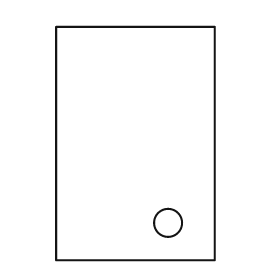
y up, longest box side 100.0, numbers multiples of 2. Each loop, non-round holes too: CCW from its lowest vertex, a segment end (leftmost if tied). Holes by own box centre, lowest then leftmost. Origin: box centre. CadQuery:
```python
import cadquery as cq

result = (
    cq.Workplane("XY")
    .moveTo(-34.0, -50.0)
    .lineTo(34.0, -50.0)
    .lineTo(34.0, 50.0)
    .lineTo(-34.0, 50.0)
    .close()
    .moveTo(14.0, -34.0)
    .circle(6.0)
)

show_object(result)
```